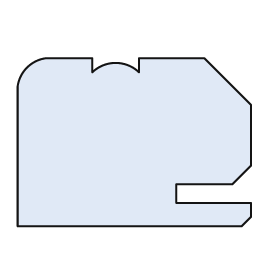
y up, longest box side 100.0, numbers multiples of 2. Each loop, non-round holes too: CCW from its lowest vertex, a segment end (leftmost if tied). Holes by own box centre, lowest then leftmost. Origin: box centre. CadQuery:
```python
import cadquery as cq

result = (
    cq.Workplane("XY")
    .moveTo(-50.0, -36.0)
    .lineTo(46.0, -36.0)
    .lineTo(50.0, -32.0)
    .lineTo(50.0, -26.0)
    .lineTo(18.0, -26.0)
    .lineTo(18.0, -18.0)
    .lineTo(42.0, -18.0)
    .lineTo(50.0, -10.0)
    .lineTo(50.0, 16.0)
    .lineTo(30.0, 36.0)
    .lineTo(2.0, 36.0)
    .lineTo(2.0, 30.0)
    .threePointArc((-8.0, 34.0), (-18.0, 30.0))
    .lineTo(-18.0, 36.0)
    .lineTo(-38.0, 36.0)
    .threePointArc((-46.0, 32.0), (-50.0, 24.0))
    .close()
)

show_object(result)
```